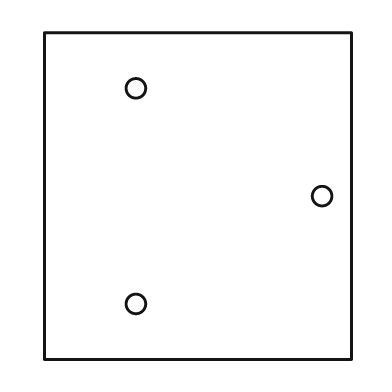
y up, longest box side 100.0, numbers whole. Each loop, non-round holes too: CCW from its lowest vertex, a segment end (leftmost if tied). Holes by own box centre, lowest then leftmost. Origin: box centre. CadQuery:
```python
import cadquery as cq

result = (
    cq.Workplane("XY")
    .moveTo(-47.0, -50.0)
    .lineTo(47.0, -50.0)
    .lineTo(47.0, 50.0)
    .lineTo(-47.0, 50.0)
    .close()
    .moveTo(-19.0, -33.0)
    .circle(3.0)
    .moveTo(38.0, 0.0)
    .circle(3.0)
    .moveTo(-19.0, 33.0)
    .circle(3.0)
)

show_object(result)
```